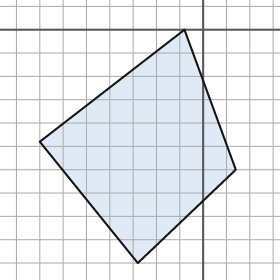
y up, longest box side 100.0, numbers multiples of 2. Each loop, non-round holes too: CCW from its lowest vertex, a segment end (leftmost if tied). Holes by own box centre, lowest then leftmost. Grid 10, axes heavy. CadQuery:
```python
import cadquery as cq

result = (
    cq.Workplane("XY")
    .moveTo(-28.0, -100.0)
    .lineTo(14.0, -60.0)
    .lineTo(-8.0, 0.0)
    .lineTo(-70.0, -48.0)
    .close()
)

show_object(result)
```